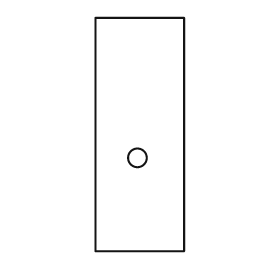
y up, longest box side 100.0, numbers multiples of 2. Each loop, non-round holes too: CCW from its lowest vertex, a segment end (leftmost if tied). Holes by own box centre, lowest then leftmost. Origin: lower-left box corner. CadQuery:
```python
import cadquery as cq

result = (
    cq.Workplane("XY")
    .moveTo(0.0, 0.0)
    .lineTo(38.0, 0.0)
    .lineTo(38.0, 100.0)
    .lineTo(0.0, 100.0)
    .close()
    .moveTo(18.0, 40.0)
    .circle(4.0)
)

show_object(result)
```